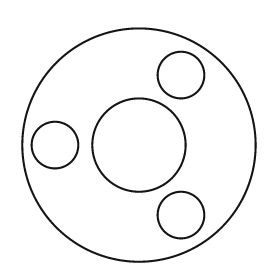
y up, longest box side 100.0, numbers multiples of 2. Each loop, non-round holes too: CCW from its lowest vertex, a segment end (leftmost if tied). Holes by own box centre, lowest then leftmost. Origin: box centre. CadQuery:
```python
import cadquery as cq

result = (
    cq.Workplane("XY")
    .moveTo(0.0, 0.0)
    .circle(50.0)
    .moveTo(18.0, -30.0)
    .circle(10.0)
    .moveTo(-36.0, 0.0)
    .circle(10.0)
    .moveTo(0.0, 0.0)
    .circle(20.0)
    .moveTo(18.0, 30.0)
    .circle(10.0)
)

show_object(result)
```